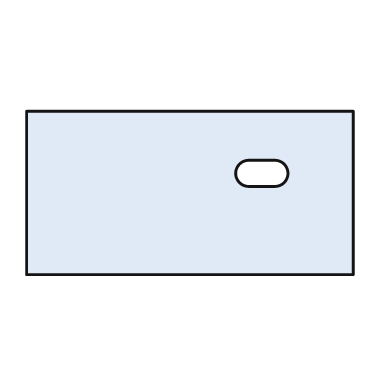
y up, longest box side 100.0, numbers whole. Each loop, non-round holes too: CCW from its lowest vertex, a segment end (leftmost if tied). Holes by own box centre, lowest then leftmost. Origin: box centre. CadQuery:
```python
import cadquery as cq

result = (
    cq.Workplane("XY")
    .moveTo(-50.0, -25.0)
    .lineTo(50.0, -25.0)
    .lineTo(50.0, 25.0)
    .lineTo(-50.0, 25.0)
    .close()
    .moveTo(18.0, 2.0)
    .lineTo(26.0, 2.0)
    .threePointArc((30.0, 6.0), (26.0, 10.0))
    .lineTo(18.0, 10.0)
    .threePointArc((14.0, 6.0), (18.0, 2.0))
    .close()
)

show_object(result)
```